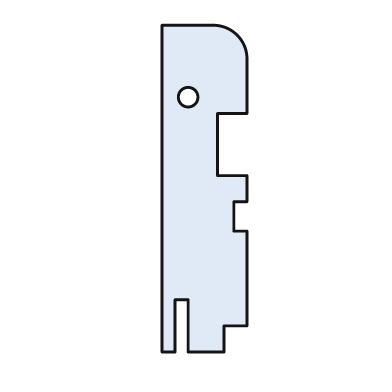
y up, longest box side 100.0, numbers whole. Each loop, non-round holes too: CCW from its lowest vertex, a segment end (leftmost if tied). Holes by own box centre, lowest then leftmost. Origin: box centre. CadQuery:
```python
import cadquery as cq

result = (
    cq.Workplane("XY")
    .moveTo(-13.0, -50.0)
    .lineTo(-9.0, -50.0)
    .lineTo(-9.0, -34.0)
    .lineTo(-5.0, -34.0)
    .lineTo(-5.0, -50.0)
    .lineTo(6.0, -50.0)
    .lineTo(6.0, -42.0)
    .lineTo(13.0, -42.0)
    .lineTo(13.0, -13.0)
    .lineTo(9.0, -13.0)
    .lineTo(9.0, -4.0)
    .lineTo(13.0, -4.0)
    .lineTo(13.0, 4.0)
    .lineTo(4.0, 4.0)
    .lineTo(4.0, 23.0)
    .lineTo(13.0, 23.0)
    .lineTo(13.0, 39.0)
    .threePointArc((10.0, 47.0), (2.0, 50.0))
    .lineTo(-13.0, 50.0)
    .close()
    .moveTo(-5.0, 28.0)
    .circle(3.0)
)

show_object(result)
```